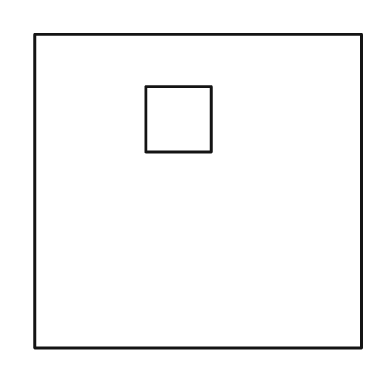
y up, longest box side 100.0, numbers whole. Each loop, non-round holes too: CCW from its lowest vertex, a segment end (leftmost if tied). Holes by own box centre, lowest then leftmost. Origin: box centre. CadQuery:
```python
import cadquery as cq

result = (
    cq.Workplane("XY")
    .moveTo(-50.0, -48.0)
    .lineTo(50.0, -48.0)
    .lineTo(50.0, 48.0)
    .lineTo(-50.0, 48.0)
    .close()
    .moveTo(-16.0, 12.0)
    .lineTo(4.0, 12.0)
    .lineTo(4.0, 32.0)
    .lineTo(-16.0, 32.0)
    .close()
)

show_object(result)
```